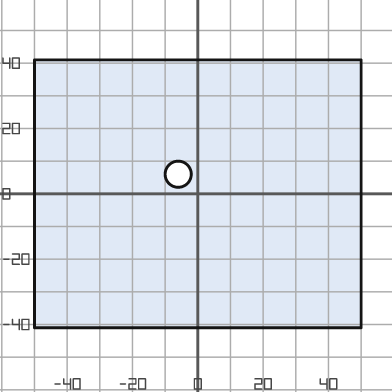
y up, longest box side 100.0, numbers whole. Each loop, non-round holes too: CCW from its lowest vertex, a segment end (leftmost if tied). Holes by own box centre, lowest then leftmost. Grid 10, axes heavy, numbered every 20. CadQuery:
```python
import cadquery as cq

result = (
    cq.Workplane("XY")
    .moveTo(-50.0, -41.0)
    .lineTo(50.0, -41.0)
    .lineTo(50.0, 41.0)
    .lineTo(-50.0, 41.0)
    .close()
    .moveTo(-6.0, 6.0)
    .circle(4.0)
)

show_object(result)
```